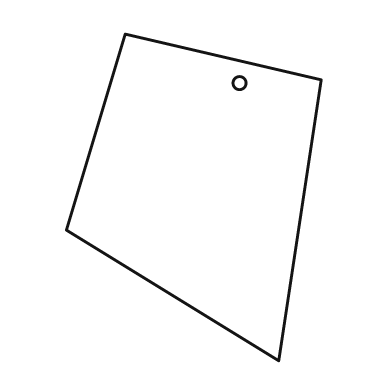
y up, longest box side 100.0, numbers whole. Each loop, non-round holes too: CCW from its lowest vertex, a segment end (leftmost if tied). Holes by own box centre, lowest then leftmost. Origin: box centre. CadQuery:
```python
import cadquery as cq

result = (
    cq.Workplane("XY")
    .moveTo(26.0, -50.0)
    .lineTo(39.0, 36.0)
    .lineTo(-21.0, 50.0)
    .lineTo(-39.0, -10.0)
    .close()
    .moveTo(14.0, 35.0)
    .circle(2.0)
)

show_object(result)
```